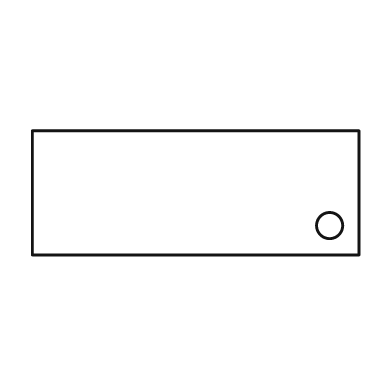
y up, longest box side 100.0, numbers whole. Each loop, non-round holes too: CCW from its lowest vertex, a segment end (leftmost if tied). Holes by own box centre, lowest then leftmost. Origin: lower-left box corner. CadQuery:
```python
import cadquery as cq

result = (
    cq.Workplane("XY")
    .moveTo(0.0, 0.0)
    .lineTo(100.0, 0.0)
    .lineTo(100.0, 38.0)
    .lineTo(0.0, 38.0)
    .close()
    .moveTo(91.0, 9.0)
    .circle(4.0)
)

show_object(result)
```